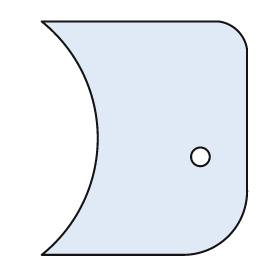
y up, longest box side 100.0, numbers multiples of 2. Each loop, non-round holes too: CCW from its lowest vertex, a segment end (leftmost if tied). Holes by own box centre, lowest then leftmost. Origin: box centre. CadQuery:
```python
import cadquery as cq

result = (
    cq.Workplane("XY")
    .moveTo(-44.0, -50.0)
    .lineTo(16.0, -50.0)
    .threePointArc((36.0, -42.0), (44.0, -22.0))
    .lineTo(44.0, 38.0)
    .threePointArc((40.0, 46.0), (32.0, 50.0))
    .lineTo(-44.0, 50.0)
    .threePointArc((-20.0, 0.0), (-44.0, -50.0))
    .close()
    .moveTo(24.0, -8.0)
    .circle(4.0)
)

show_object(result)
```